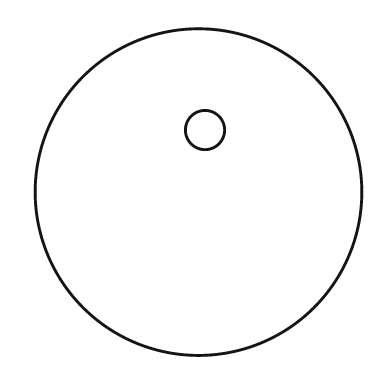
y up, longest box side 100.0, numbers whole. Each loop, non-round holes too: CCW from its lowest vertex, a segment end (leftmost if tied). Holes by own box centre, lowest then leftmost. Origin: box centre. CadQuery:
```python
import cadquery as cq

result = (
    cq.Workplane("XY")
    .moveTo(0.0, 0.0)
    .circle(50.0)
    .moveTo(2.0, 19.0)
    .circle(6.0)
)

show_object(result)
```